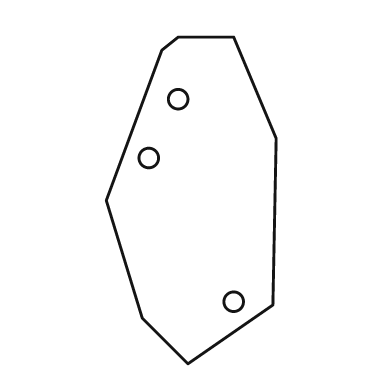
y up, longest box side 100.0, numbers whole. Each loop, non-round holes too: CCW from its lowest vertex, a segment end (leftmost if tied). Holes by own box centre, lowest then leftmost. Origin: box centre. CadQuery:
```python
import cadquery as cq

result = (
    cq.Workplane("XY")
    .moveTo(-1.0, -50.0)
    .lineTo(25.0, -32.0)
    .lineTo(26.0, 19.0)
    .lineTo(13.0, 50.0)
    .lineTo(-4.0, 50.0)
    .lineTo(-9.0, 46.0)
    .lineTo(-26.0, 0.0)
    .lineTo(-15.0, -36.0)
    .close()
    .moveTo(13.0, -31.0)
    .circle(3.0)
    .moveTo(-13.0, 13.0)
    .circle(3.0)
    .moveTo(-4.0, 31.0)
    .circle(3.0)
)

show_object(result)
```